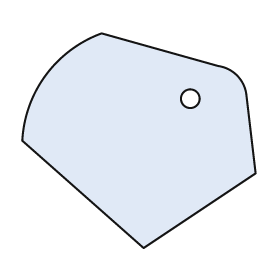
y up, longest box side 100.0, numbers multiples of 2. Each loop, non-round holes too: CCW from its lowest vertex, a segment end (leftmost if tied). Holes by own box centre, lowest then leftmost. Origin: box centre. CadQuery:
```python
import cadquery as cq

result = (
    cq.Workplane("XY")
    .moveTo(2.0, -46.0)
    .lineTo(50.0, -14.0)
    .lineTo(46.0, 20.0)
    .threePointArc((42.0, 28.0), (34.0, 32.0))
    .lineTo(-16.0, 46.0)
    .threePointArc((-40.0, 28.0), (-50.0, 0.0))
    .close()
    .moveTo(22.0, 18.0)
    .circle(4.0)
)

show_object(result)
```